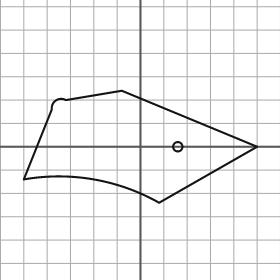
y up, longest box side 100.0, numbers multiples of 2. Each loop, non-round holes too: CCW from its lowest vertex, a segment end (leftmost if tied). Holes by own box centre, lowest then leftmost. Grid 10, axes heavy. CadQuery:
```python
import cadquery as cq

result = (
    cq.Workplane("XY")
    .moveTo(8.0, -24.0)
    .lineTo(50.0, 0.0)
    .lineTo(-8.0, 24.0)
    .lineTo(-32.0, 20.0)
    .threePointArc((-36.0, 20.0), (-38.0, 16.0))
    .lineTo(-50.0, -14.0)
    .threePointArc((-20.0, -14.0), (8.0, -24.0))
    .close()
    .moveTo(16.0, 0.0)
    .circle(2.0)
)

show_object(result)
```